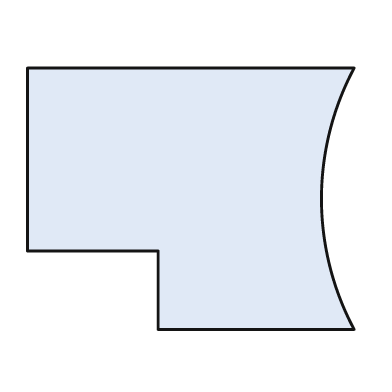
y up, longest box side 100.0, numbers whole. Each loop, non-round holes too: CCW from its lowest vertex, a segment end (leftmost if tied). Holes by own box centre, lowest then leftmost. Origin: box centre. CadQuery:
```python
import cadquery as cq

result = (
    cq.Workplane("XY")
    .moveTo(-10.0, -40.0)
    .lineTo(50.0, -40.0)
    .threePointArc((40.0, 0.0), (50.0, 40.0))
    .lineTo(-50.0, 40.0)
    .lineTo(-50.0, -16.0)
    .lineTo(-10.0, -16.0)
    .close()
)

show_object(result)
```